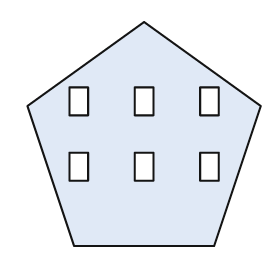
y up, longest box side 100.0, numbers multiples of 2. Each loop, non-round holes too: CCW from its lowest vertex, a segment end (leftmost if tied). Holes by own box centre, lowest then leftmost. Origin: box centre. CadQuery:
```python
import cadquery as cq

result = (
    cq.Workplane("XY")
    .moveTo(-30.0, -48.0)
    .lineTo(30.0, -48.0)
    .lineTo(50.0, 12.0)
    .lineTo(0.0, 48.0)
    .lineTo(-50.0, 12.0)
    .close()
    .moveTo(-32.0, -20.0)
    .lineTo(-24.0, -20.0)
    .lineTo(-24.0, -8.0)
    .lineTo(-32.0, -8.0)
    .close()
    .moveTo(-4.0, -20.0)
    .lineTo(4.0, -20.0)
    .lineTo(4.0, -8.0)
    .lineTo(-4.0, -8.0)
    .close()
    .moveTo(24.0, -20.0)
    .lineTo(32.0, -20.0)
    .lineTo(32.0, -8.0)
    .lineTo(24.0, -8.0)
    .close()
    .moveTo(-32.0, 8.0)
    .lineTo(-24.0, 8.0)
    .lineTo(-24.0, 20.0)
    .lineTo(-32.0, 20.0)
    .close()
    .moveTo(-4.0, 8.0)
    .lineTo(4.0, 8.0)
    .lineTo(4.0, 20.0)
    .lineTo(-4.0, 20.0)
    .close()
    .moveTo(24.0, 8.0)
    .lineTo(32.0, 8.0)
    .lineTo(32.0, 20.0)
    .lineTo(24.0, 20.0)
    .close()
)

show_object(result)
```